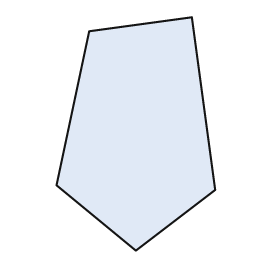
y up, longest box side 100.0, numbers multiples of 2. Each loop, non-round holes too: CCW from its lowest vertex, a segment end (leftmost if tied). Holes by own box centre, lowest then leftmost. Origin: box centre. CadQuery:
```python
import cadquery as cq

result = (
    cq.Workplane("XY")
    .moveTo(0.0, -50.0)
    .lineTo(34.0, -24.0)
    .lineTo(24.0, 50.0)
    .lineTo(-20.0, 44.0)
    .lineTo(-34.0, -22.0)
    .close()
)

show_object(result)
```